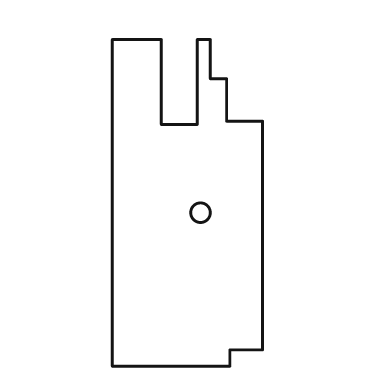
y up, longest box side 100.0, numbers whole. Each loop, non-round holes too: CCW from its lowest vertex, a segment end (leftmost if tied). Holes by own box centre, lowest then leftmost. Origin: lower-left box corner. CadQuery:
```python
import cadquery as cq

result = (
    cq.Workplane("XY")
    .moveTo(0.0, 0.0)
    .lineTo(36.0, 0.0)
    .lineTo(36.0, 5.0)
    .lineTo(46.0, 5.0)
    .lineTo(46.0, 75.0)
    .lineTo(35.0, 75.0)
    .lineTo(35.0, 88.0)
    .lineTo(30.0, 88.0)
    .lineTo(30.0, 100.0)
    .lineTo(26.0, 100.0)
    .lineTo(26.0, 74.0)
    .lineTo(15.0, 74.0)
    .lineTo(15.0, 100.0)
    .lineTo(0.0, 100.0)
    .close()
    .moveTo(27.0, 47.0)
    .circle(3.0)
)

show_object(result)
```